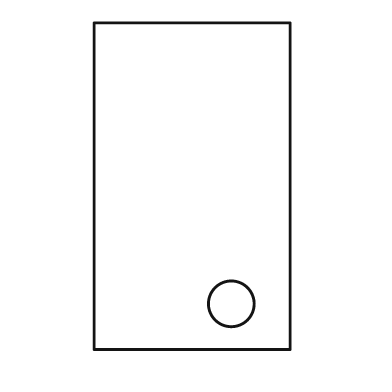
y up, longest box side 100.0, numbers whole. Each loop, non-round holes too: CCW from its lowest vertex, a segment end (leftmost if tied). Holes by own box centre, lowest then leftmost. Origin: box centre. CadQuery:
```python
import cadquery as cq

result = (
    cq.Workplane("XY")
    .moveTo(-30.0, -50.0)
    .lineTo(30.0, -50.0)
    .lineTo(30.0, 50.0)
    .lineTo(-30.0, 50.0)
    .close()
    .moveTo(12.0, -36.0)
    .circle(7.0)
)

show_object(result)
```